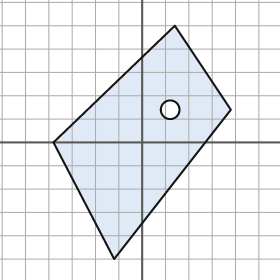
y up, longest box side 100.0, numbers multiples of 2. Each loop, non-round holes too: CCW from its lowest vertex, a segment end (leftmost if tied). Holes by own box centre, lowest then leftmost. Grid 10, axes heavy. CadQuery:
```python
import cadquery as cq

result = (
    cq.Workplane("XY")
    .moveTo(-12.0, -50.0)
    .lineTo(38.0, 14.0)
    .lineTo(14.0, 50.0)
    .lineTo(-38.0, 0.0)
    .close()
    .moveTo(12.0, 14.0)
    .circle(4.0)
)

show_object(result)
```